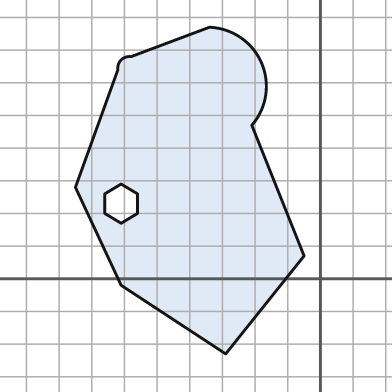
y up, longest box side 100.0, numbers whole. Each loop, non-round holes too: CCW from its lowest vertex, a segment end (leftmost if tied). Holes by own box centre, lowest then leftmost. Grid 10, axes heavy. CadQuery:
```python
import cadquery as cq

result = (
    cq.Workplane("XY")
    .moveTo(-29.0, -23.0)
    .lineTo(-5.0, 7.0)
    .lineTo(-21.0, 47.0)
    .threePointArc((-18.0, 66.0), (-34.0, 77.0))
    .lineTo(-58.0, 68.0)
    .threePointArc((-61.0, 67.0), (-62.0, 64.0))
    .lineTo(-75.0, 28.0)
    .lineTo(-61.0, -2.0)
    .close()
    .moveTo(-61.0, 17.0)
    .lineTo(-56.0, 20.0)
    .lineTo(-56.0, 26.0)
    .lineTo(-61.0, 29.0)
    .lineTo(-66.0, 26.0)
    .lineTo(-66.0, 20.0)
    .close()
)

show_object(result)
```